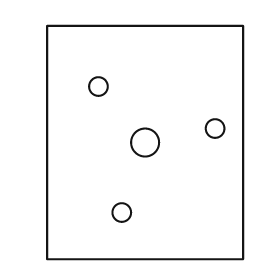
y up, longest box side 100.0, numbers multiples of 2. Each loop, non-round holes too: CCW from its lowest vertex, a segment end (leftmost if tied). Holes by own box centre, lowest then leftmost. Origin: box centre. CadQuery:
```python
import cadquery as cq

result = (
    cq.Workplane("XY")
    .moveTo(-42.0, -50.0)
    .lineTo(42.0, -50.0)
    .lineTo(42.0, 50.0)
    .lineTo(-42.0, 50.0)
    .close()
    .moveTo(-10.0, -30.0)
    .circle(4.0)
    .moveTo(0.0, 0.0)
    .circle(6.0)
    .moveTo(30.0, 6.0)
    .circle(4.0)
    .moveTo(-20.0, 24.0)
    .circle(4.0)
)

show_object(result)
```